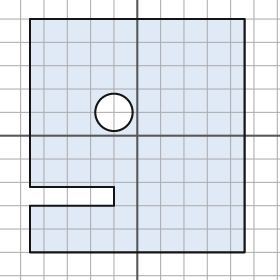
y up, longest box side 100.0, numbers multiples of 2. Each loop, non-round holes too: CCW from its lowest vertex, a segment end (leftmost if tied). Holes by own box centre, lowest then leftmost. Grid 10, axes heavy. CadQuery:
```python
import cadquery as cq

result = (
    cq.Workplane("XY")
    .moveTo(-46.0, -50.0)
    .lineTo(46.0, -50.0)
    .lineTo(46.0, 50.0)
    .lineTo(-46.0, 50.0)
    .lineTo(-46.0, -22.0)
    .lineTo(-10.0, -22.0)
    .lineTo(-10.0, -30.0)
    .lineTo(-46.0, -30.0)
    .close()
    .moveTo(-10.0, 10.0)
    .circle(8.0)
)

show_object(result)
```